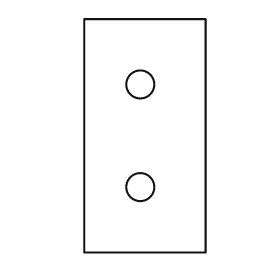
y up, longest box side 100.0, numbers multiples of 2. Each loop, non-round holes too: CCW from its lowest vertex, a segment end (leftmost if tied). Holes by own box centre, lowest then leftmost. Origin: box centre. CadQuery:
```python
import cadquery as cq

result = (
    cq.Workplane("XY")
    .moveTo(-26.0, -50.0)
    .lineTo(26.0, -50.0)
    .lineTo(26.0, 50.0)
    .lineTo(-26.0, 50.0)
    .close()
    .moveTo(-2.0, -22.0)
    .circle(6.0)
    .moveTo(-2.0, 22.0)
    .circle(6.0)
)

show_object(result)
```